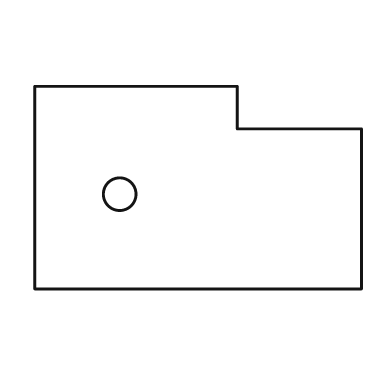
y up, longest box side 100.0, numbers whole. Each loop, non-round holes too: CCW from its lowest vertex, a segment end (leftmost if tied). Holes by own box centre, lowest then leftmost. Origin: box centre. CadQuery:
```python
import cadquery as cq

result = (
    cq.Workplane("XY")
    .moveTo(-50.0, -31.0)
    .lineTo(50.0, -31.0)
    .lineTo(50.0, 18.0)
    .lineTo(12.0, 18.0)
    .lineTo(12.0, 31.0)
    .lineTo(-50.0, 31.0)
    .close()
    .moveTo(-24.0, -2.0)
    .circle(5.0)
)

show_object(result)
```